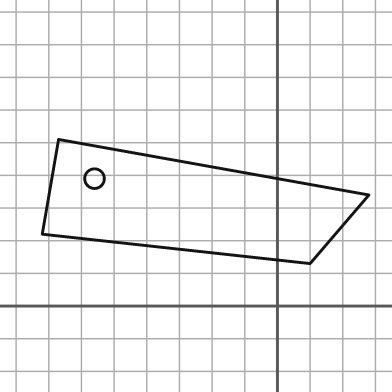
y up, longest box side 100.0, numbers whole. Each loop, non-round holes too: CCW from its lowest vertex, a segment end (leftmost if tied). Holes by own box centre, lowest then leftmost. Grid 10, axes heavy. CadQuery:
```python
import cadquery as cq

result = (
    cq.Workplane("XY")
    .moveTo(10.0, 13.0)
    .lineTo(28.0, 34.0)
    .lineTo(-67.0, 51.0)
    .lineTo(-72.0, 22.0)
    .close()
    .moveTo(-56.0, 39.0)
    .circle(3.0)
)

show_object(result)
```